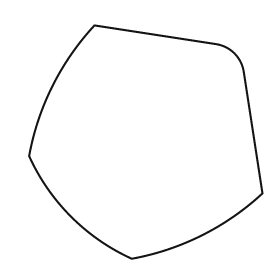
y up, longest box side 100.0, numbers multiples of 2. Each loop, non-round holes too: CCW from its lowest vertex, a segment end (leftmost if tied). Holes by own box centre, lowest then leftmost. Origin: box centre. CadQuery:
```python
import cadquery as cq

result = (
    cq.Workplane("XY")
    .moveTo(-6.0, -50.0)
    .threePointArc((24.0, -40.0), (50.0, -22.0))
    .lineTo(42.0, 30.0)
    .threePointArc((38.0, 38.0), (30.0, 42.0))
    .lineTo(-22.0, 50.0)
    .threePointArc((-40.0, 24.0), (-50.0, -6.0))
    .threePointArc((-32.0, -32.0), (-6.0, -50.0))
    .close()
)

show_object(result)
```